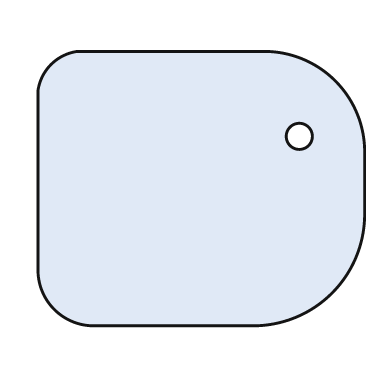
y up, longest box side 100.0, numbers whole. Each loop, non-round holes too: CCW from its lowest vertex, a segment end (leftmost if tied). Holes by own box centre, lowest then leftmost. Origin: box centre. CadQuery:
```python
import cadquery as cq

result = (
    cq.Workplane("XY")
    .moveTo(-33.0, -42.0)
    .lineTo(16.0, -42.0)
    .threePointArc((40.0, -32.0), (50.0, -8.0))
    .lineTo(50.0, 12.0)
    .threePointArc((41.0, 33.0), (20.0, 42.0))
    .lineTo(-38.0, 42.0)
    .threePointArc((-46.0, 38.0), (-50.0, 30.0))
    .lineTo(-50.0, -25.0)
    .threePointArc((-45.0, -37.0), (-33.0, -42.0))
    .close()
    .moveTo(30.0, 16.0)
    .circle(4.0)
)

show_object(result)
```